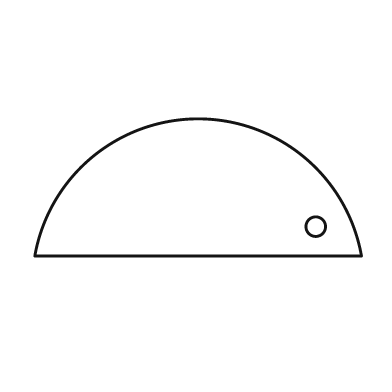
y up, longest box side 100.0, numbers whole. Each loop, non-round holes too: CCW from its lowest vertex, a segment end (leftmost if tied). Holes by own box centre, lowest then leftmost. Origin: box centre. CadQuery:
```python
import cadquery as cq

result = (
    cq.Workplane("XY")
    .moveTo(-50.0, -21.0)
    .lineTo(50.0, -21.0)
    .threePointArc((0.0, 21.0), (-50.0, -21.0))
    .close()
    .moveTo(36.0, -12.0)
    .circle(3.0)
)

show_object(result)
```